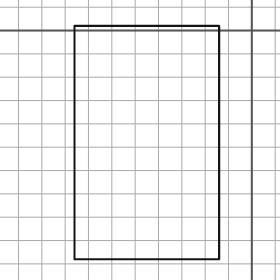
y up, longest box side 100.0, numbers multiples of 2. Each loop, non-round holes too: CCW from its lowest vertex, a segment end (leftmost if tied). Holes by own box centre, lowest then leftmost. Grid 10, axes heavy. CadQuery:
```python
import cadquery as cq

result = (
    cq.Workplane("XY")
    .moveTo(-76.0, -98.0)
    .lineTo(-14.0, -98.0)
    .lineTo(-14.0, 2.0)
    .lineTo(-76.0, 2.0)
    .close()
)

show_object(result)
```